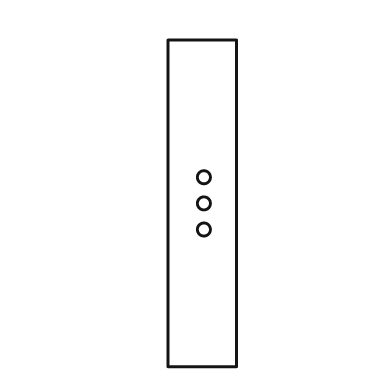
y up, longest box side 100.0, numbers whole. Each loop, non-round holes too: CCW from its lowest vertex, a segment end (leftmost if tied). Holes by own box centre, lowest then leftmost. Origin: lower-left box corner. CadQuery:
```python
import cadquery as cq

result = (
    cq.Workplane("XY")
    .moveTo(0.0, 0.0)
    .lineTo(21.0, 0.0)
    .lineTo(21.0, 100.0)
    .lineTo(0.0, 100.0)
    .close()
    .moveTo(11.0, 42.0)
    .circle(2.0)
    .moveTo(11.0, 50.0)
    .circle(2.0)
    .moveTo(11.0, 58.0)
    .circle(2.0)
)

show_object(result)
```